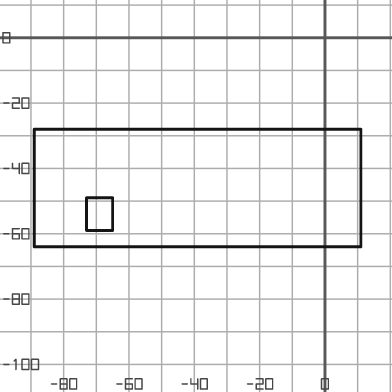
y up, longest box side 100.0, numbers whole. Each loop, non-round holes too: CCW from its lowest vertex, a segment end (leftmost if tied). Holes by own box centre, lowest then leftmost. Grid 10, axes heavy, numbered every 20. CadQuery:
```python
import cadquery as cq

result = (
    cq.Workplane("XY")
    .moveTo(-89.0, -64.0)
    .lineTo(11.0, -64.0)
    .lineTo(11.0, -28.0)
    .lineTo(-89.0, -28.0)
    .close()
    .moveTo(-73.0, -59.0)
    .lineTo(-65.0, -59.0)
    .lineTo(-65.0, -49.0)
    .lineTo(-73.0, -49.0)
    .close()
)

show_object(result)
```